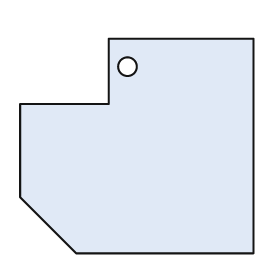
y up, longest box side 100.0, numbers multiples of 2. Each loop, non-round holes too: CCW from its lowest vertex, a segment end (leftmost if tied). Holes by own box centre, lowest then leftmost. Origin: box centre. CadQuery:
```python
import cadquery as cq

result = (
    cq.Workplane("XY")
    .moveTo(-26.0, -46.0)
    .lineTo(50.0, -46.0)
    .lineTo(50.0, 46.0)
    .lineTo(-12.0, 46.0)
    .lineTo(-12.0, 18.0)
    .lineTo(-50.0, 18.0)
    .lineTo(-50.0, -22.0)
    .close()
    .moveTo(-4.0, 34.0)
    .circle(4.0)
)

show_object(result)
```